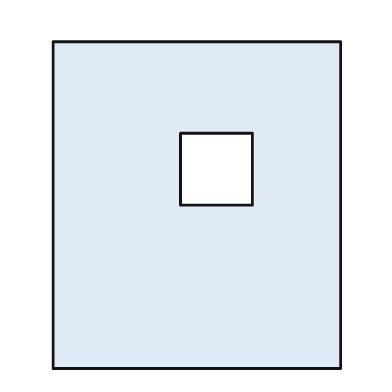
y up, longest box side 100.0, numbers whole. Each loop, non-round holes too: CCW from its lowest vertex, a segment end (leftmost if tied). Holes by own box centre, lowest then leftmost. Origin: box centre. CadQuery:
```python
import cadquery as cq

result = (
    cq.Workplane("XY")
    .moveTo(-44.0, -50.0)
    .lineTo(44.0, -50.0)
    .lineTo(44.0, 50.0)
    .lineTo(-44.0, 50.0)
    .close()
    .moveTo(-5.0, 0.0)
    .lineTo(17.0, 0.0)
    .lineTo(17.0, 22.0)
    .lineTo(-5.0, 22.0)
    .close()
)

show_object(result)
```